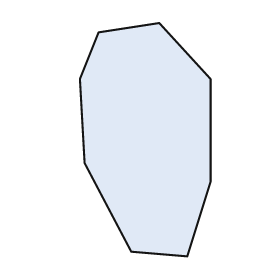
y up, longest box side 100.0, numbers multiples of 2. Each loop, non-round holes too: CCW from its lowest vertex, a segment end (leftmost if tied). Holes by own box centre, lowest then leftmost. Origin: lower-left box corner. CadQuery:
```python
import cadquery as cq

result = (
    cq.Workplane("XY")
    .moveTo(46.0, 0.0)
    .lineTo(56.0, 32.0)
    .lineTo(56.0, 76.0)
    .lineTo(34.0, 100.0)
    .lineTo(8.0, 96.0)
    .lineTo(0.0, 76.0)
    .lineTo(2.0, 40.0)
    .lineTo(22.0, 2.0)
    .close()
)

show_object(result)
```